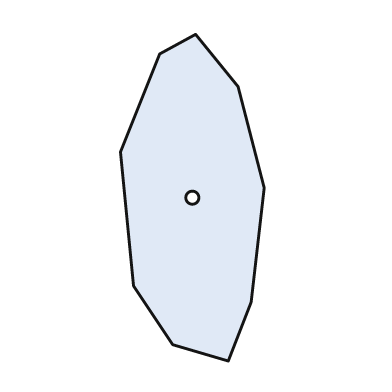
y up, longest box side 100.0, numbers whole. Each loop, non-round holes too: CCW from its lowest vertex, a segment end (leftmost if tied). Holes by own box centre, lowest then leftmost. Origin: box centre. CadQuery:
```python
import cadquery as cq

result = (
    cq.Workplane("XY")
    .moveTo(11.0, -50.0)
    .lineTo(18.0, -32.0)
    .lineTo(22.0, 3.0)
    .lineTo(14.0, 34.0)
    .lineTo(1.0, 50.0)
    .lineTo(-10.0, 44.0)
    .lineTo(-22.0, 14.0)
    .lineTo(-18.0, -27.0)
    .lineTo(-6.0, -45.0)
    .close()
    .moveTo(0.0, 0.0)
    .circle(2.0)
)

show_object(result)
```